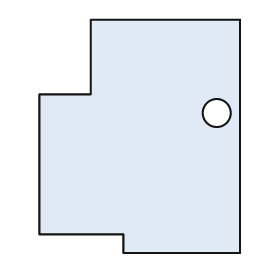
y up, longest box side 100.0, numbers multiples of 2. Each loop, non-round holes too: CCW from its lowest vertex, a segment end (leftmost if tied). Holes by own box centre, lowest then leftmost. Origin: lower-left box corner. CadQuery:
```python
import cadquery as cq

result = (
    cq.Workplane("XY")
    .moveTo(36.0, 0.0)
    .lineTo(86.0, 0.0)
    .lineTo(86.0, 100.0)
    .lineTo(22.0, 100.0)
    .lineTo(22.0, 68.0)
    .lineTo(0.0, 68.0)
    .lineTo(0.0, 8.0)
    .lineTo(36.0, 8.0)
    .close()
    .moveTo(76.0, 60.0)
    .circle(6.0)
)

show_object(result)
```